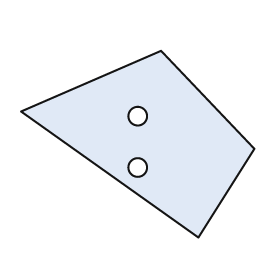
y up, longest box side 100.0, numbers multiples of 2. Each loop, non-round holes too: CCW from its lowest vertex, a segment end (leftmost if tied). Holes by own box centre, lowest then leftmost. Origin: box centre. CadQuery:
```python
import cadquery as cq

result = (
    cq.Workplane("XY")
    .moveTo(26.0, -40.0)
    .lineTo(50.0, -2.0)
    .lineTo(10.0, 40.0)
    .lineTo(-50.0, 14.0)
    .close()
    .moveTo(0.0, -10.0)
    .circle(4.0)
    .moveTo(0.0, 12.0)
    .circle(4.0)
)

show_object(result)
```